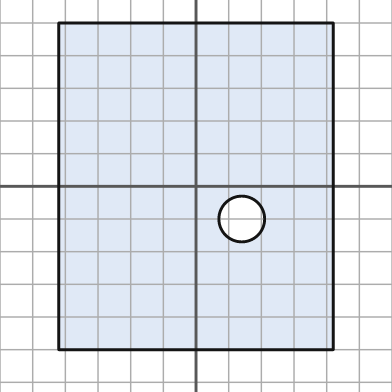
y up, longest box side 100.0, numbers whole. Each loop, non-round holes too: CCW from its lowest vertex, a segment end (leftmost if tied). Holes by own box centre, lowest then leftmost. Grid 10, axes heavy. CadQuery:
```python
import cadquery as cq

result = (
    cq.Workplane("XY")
    .moveTo(-42.0, -50.0)
    .lineTo(42.0, -50.0)
    .lineTo(42.0, 50.0)
    .lineTo(-42.0, 50.0)
    .close()
    .moveTo(14.0, -10.0)
    .circle(7.0)
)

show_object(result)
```